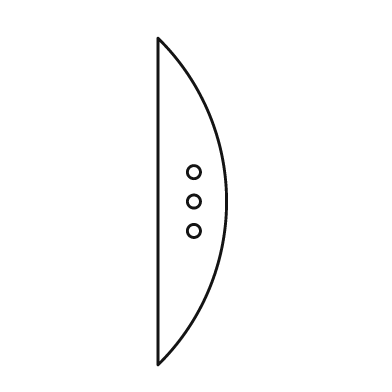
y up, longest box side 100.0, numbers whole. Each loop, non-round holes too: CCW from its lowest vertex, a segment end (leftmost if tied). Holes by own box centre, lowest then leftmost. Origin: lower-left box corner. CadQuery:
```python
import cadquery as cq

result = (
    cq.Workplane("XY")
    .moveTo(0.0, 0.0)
    .threePointArc((21.0, 50.0), (0.0, 100.0))
    .close()
    .moveTo(11.0, 41.0)
    .circle(2.0)
    .moveTo(11.0, 50.0)
    .circle(2.0)
    .moveTo(11.0, 59.0)
    .circle(2.0)
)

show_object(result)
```